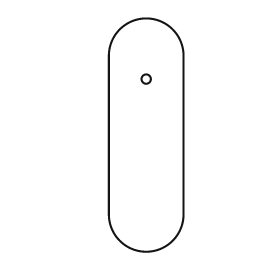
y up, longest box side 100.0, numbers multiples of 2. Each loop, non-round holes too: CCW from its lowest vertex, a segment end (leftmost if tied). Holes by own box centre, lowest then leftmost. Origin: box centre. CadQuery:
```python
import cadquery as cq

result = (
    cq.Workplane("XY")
    .moveTo(-16.0, -34.0)
    .threePointArc((0.0, -50.0), (16.0, -34.0))
    .lineTo(16.0, 34.0)
    .threePointArc((0.0, 50.0), (-16.0, 34.0))
    .close()
    .moveTo(0.0, 24.0)
    .circle(2.0)
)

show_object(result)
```